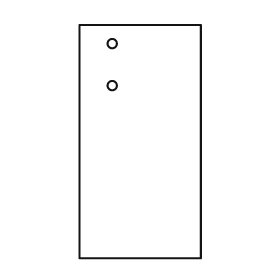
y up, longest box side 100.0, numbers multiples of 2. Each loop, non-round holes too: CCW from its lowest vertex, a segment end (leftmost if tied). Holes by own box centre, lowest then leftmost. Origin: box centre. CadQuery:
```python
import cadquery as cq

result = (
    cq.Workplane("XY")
    .moveTo(-26.0, -50.0)
    .lineTo(26.0, -50.0)
    .lineTo(26.0, 50.0)
    .lineTo(-26.0, 50.0)
    .close()
    .moveTo(-12.0, 24.0)
    .circle(2.0)
    .moveTo(-12.0, 42.0)
    .circle(2.0)
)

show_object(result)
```